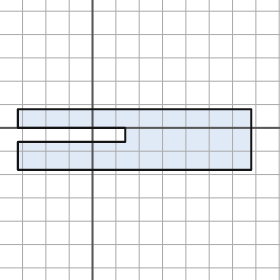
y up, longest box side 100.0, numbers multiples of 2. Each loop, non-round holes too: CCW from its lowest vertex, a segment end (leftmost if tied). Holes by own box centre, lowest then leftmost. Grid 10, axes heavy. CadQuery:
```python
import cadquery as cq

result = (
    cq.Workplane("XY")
    .moveTo(-32.0, -18.0)
    .lineTo(68.0, -18.0)
    .lineTo(68.0, 8.0)
    .lineTo(-32.0, 8.0)
    .lineTo(-32.0, 0.0)
    .lineTo(14.0, 0.0)
    .lineTo(14.0, -6.0)
    .lineTo(-32.0, -6.0)
    .close()
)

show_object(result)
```